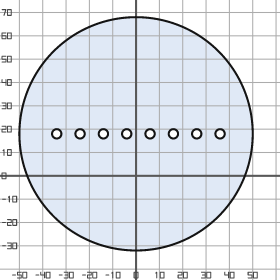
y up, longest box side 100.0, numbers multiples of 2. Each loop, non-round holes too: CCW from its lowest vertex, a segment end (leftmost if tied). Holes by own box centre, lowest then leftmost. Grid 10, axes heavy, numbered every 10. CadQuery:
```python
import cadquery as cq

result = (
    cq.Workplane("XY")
    .moveTo(0.0, 18.0)
    .circle(50.0)
    .moveTo(-34.0, 18.0)
    .circle(2.0)
    .moveTo(-24.0, 18.0)
    .circle(2.0)
    .moveTo(-14.0, 18.0)
    .circle(2.0)
    .moveTo(-4.0, 18.0)
    .circle(2.0)
    .moveTo(6.0, 18.0)
    .circle(2.0)
    .moveTo(16.0, 18.0)
    .circle(2.0)
    .moveTo(26.0, 18.0)
    .circle(2.0)
    .moveTo(36.0, 18.0)
    .circle(2.0)
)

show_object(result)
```